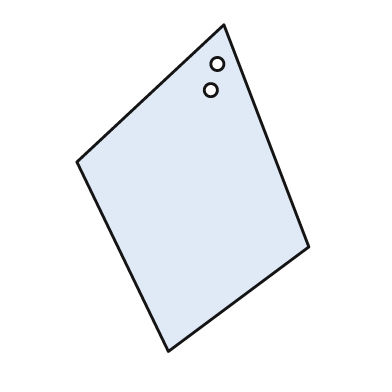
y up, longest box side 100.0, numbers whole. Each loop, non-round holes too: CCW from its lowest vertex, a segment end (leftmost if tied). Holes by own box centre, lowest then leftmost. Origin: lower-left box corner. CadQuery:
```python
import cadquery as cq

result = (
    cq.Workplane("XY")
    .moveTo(28.0, 0.0)
    .lineTo(71.0, 32.0)
    .lineTo(45.0, 100.0)
    .lineTo(0.0, 58.0)
    .close()
    .moveTo(41.0, 80.0)
    .circle(2.0)
    .moveTo(43.0, 88.0)
    .circle(2.0)
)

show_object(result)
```